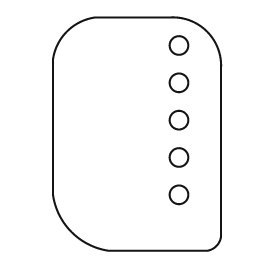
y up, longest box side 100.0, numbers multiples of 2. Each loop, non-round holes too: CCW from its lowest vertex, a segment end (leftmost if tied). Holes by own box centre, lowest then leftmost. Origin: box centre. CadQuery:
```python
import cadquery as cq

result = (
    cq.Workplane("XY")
    .moveTo(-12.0, -50.0)
    .lineTo(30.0, -50.0)
    .threePointArc((34.0, -48.0), (36.0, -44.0))
    .lineTo(36.0, 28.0)
    .threePointArc((30.0, 44.0), (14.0, 50.0))
    .lineTo(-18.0, 50.0)
    .threePointArc((-30.0, 44.0), (-36.0, 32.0))
    .lineTo(-36.0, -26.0)
    .threePointArc((-28.0, -42.0), (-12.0, -50.0))
    .close()
    .moveTo(18.0, -26.0)
    .circle(4.0)
    .moveTo(18.0, -10.0)
    .circle(4.0)
    .moveTo(18.0, 6.0)
    .circle(4.0)
    .moveTo(18.0, 22.0)
    .circle(4.0)
    .moveTo(18.0, 38.0)
    .circle(4.0)
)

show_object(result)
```